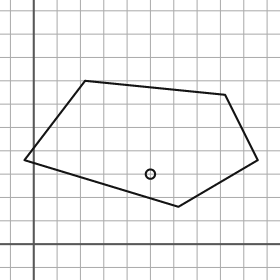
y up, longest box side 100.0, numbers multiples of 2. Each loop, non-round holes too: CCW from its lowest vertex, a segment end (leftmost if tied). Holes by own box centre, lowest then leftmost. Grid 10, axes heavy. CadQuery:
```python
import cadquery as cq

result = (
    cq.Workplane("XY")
    .moveTo(62.0, 16.0)
    .lineTo(96.0, 36.0)
    .lineTo(82.0, 64.0)
    .lineTo(22.0, 70.0)
    .lineTo(-4.0, 36.0)
    .close()
    .moveTo(50.0, 30.0)
    .circle(2.0)
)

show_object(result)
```